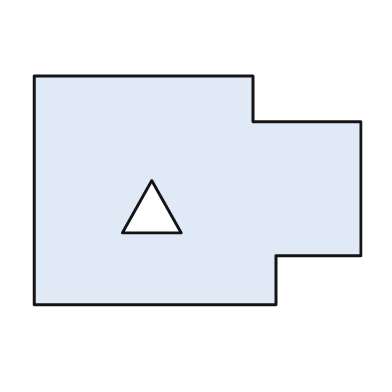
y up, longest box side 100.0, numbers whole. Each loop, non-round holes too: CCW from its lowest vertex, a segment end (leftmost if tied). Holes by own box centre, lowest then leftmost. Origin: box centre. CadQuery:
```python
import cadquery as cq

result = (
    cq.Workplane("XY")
    .moveTo(-50.0, -35.0)
    .lineTo(24.0, -35.0)
    .lineTo(24.0, -20.0)
    .lineTo(50.0, -20.0)
    .lineTo(50.0, 21.0)
    .lineTo(17.0, 21.0)
    .lineTo(17.0, 35.0)
    .lineTo(-50.0, 35.0)
    .close()
    .moveTo(-23.0, -13.0)
    .lineTo(-5.0, -13.0)
    .lineTo(-14.0, 3.0)
    .close()
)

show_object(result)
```